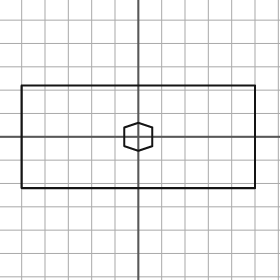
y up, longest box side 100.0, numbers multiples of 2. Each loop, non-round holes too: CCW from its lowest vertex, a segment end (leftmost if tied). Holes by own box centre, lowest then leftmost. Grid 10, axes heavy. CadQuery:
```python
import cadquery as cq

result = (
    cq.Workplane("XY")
    .moveTo(-50.0, -22.0)
    .lineTo(50.0, -22.0)
    .lineTo(50.0, 22.0)
    .lineTo(-50.0, 22.0)
    .close()
    .moveTo(0.0, -6.0)
    .lineTo(6.0, -4.0)
    .lineTo(6.0, 4.0)
    .lineTo(0.0, 6.0)
    .lineTo(-6.0, 4.0)
    .lineTo(-6.0, -4.0)
    .close()
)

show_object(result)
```